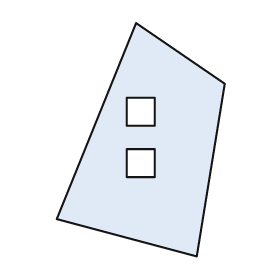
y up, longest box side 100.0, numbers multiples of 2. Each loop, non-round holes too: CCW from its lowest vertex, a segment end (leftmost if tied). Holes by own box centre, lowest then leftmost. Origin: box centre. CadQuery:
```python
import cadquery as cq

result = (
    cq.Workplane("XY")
    .moveTo(24.0, -50.0)
    .lineTo(36.0, 24.0)
    .lineTo(-2.0, 50.0)
    .lineTo(-36.0, -34.0)
    .close()
    .moveTo(-6.0, -16.0)
    .lineTo(6.0, -16.0)
    .lineTo(6.0, -4.0)
    .lineTo(-6.0, -4.0)
    .close()
    .moveTo(-6.0, 6.0)
    .lineTo(6.0, 6.0)
    .lineTo(6.0, 18.0)
    .lineTo(-6.0, 18.0)
    .close()
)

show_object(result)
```